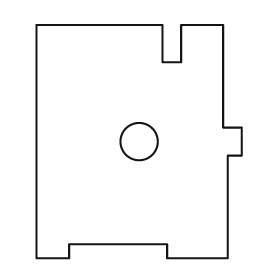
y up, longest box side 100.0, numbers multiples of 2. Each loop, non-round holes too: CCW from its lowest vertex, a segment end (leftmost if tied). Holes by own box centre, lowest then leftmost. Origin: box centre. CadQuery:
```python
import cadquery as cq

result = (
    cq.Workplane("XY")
    .moveTo(-44.0, -50.0)
    .lineTo(-30.0, -50.0)
    .lineTo(-30.0, -44.0)
    .lineTo(12.0, -44.0)
    .lineTo(12.0, -50.0)
    .lineTo(38.0, -50.0)
    .lineTo(38.0, -6.0)
    .lineTo(44.0, -6.0)
    .lineTo(44.0, 6.0)
    .lineTo(36.0, 6.0)
    .lineTo(36.0, 50.0)
    .lineTo(18.0, 50.0)
    .lineTo(18.0, 34.0)
    .lineTo(10.0, 34.0)
    .lineTo(10.0, 50.0)
    .lineTo(-44.0, 50.0)
    .close()
    .moveTo(0.0, 0.0)
    .circle(8.0)
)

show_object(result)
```